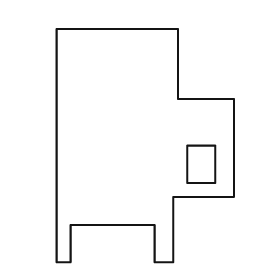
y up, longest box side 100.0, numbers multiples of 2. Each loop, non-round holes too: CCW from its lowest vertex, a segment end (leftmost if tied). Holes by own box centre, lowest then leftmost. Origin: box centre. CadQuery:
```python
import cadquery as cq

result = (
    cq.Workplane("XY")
    .moveTo(-38.0, -50.0)
    .lineTo(-32.0, -50.0)
    .lineTo(-32.0, -34.0)
    .lineTo(4.0, -34.0)
    .lineTo(4.0, -50.0)
    .lineTo(12.0, -50.0)
    .lineTo(12.0, -22.0)
    .lineTo(38.0, -22.0)
    .lineTo(38.0, 20.0)
    .lineTo(14.0, 20.0)
    .lineTo(14.0, 50.0)
    .lineTo(-38.0, 50.0)
    .close()
    .moveTo(18.0, -16.0)
    .lineTo(30.0, -16.0)
    .lineTo(30.0, 0.0)
    .lineTo(18.0, 0.0)
    .close()
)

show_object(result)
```